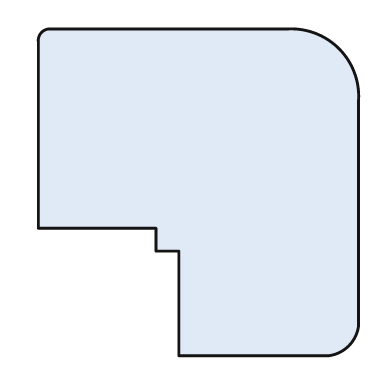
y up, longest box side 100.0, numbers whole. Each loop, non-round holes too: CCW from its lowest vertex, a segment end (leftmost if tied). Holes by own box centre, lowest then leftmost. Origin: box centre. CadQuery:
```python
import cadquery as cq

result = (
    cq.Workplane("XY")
    .moveTo(-6.0, -50.0)
    .lineTo(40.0, -50.0)
    .threePointArc((46.0, -47.0), (49.0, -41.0))
    .lineTo(49.0, 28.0)
    .threePointArc((43.0, 44.0), (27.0, 50.0))
    .lineTo(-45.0, 50.0)
    .threePointArc((-48.0, 49.0), (-49.0, 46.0))
    .lineTo(-49.0, -11.0)
    .lineTo(-13.0, -11.0)
    .lineTo(-13.0, -18.0)
    .lineTo(-6.0, -18.0)
    .close()
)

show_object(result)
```